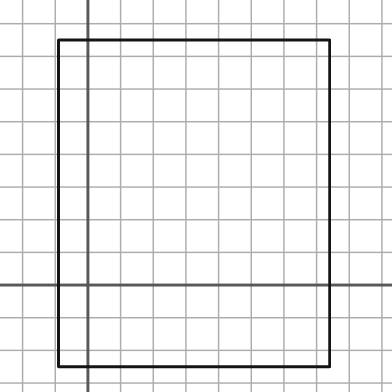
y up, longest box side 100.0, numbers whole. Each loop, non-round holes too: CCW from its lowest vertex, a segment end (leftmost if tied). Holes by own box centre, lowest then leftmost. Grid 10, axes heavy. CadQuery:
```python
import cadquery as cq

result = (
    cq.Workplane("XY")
    .moveTo(-9.0, -25.0)
    .lineTo(74.0, -25.0)
    .lineTo(74.0, 75.0)
    .lineTo(-9.0, 75.0)
    .close()
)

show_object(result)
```